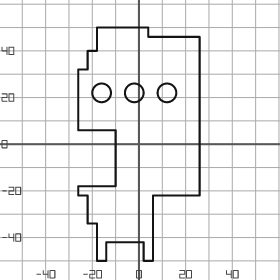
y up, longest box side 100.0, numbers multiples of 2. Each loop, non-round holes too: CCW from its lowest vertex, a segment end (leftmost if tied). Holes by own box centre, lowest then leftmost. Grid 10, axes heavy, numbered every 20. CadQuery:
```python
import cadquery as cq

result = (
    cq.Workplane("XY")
    .moveTo(-18.0, -50.0)
    .lineTo(-14.0, -50.0)
    .lineTo(-14.0, -42.0)
    .lineTo(2.0, -42.0)
    .lineTo(2.0, -50.0)
    .lineTo(6.0, -50.0)
    .lineTo(6.0, -22.0)
    .lineTo(26.0, -22.0)
    .lineTo(26.0, 46.0)
    .lineTo(4.0, 46.0)
    .lineTo(4.0, 50.0)
    .lineTo(-18.0, 50.0)
    .lineTo(-18.0, 40.0)
    .lineTo(-22.0, 40.0)
    .lineTo(-22.0, 32.0)
    .lineTo(-26.0, 32.0)
    .lineTo(-26.0, 6.0)
    .lineTo(-10.0, 6.0)
    .lineTo(-10.0, -18.0)
    .lineTo(-26.0, -18.0)
    .lineTo(-26.0, -22.0)
    .lineTo(-22.0, -22.0)
    .lineTo(-22.0, -34.0)
    .lineTo(-18.0, -34.0)
    .close()
    .moveTo(-16.0, 22.0)
    .circle(4.0)
    .moveTo(-2.0, 22.0)
    .circle(4.0)
    .moveTo(12.0, 22.0)
    .circle(4.0)
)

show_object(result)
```